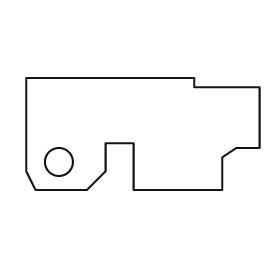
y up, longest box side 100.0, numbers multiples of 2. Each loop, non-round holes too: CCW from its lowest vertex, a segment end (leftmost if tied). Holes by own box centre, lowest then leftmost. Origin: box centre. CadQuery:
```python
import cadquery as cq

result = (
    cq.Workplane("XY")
    .moveTo(-46.0, -24.0)
    .lineTo(-24.0, -24.0)
    .lineTo(-16.0, -16.0)
    .lineTo(-16.0, -4.0)
    .lineTo(-4.0, -4.0)
    .lineTo(-4.0, -24.0)
    .lineTo(34.0, -24.0)
    .lineTo(34.0, -10.0)
    .lineTo(40.0, -6.0)
    .lineTo(50.0, -6.0)
    .lineTo(50.0, 20.0)
    .lineTo(22.0, 20.0)
    .lineTo(22.0, 24.0)
    .lineTo(-50.0, 24.0)
    .lineTo(-50.0, -16.0)
    .close()
    .moveTo(-36.0, -12.0)
    .circle(6.0)
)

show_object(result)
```